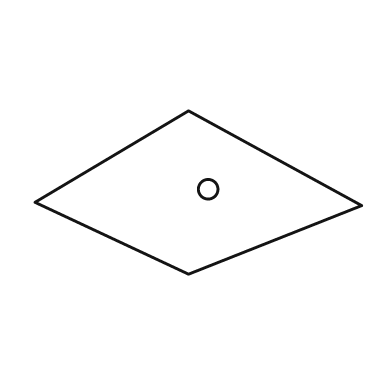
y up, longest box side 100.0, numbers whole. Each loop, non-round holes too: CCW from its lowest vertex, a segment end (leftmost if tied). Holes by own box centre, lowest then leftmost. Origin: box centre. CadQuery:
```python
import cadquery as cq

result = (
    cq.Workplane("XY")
    .moveTo(-3.0, -25.0)
    .lineTo(50.0, -4.0)
    .lineTo(-3.0, 25.0)
    .lineTo(-50.0, -3.0)
    .close()
    .moveTo(3.0, 1.0)
    .circle(3.0)
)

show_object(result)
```